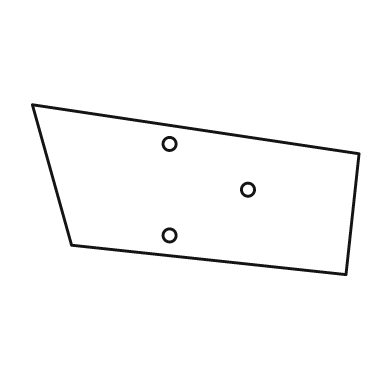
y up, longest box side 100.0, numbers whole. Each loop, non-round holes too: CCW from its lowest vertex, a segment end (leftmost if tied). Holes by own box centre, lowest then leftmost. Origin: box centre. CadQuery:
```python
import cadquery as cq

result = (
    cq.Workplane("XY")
    .moveTo(46.0, -26.0)
    .lineTo(50.0, 11.0)
    .lineTo(-50.0, 26.0)
    .lineTo(-38.0, -17.0)
    .close()
    .moveTo(-8.0, -14.0)
    .circle(2.0)
    .moveTo(16.0, 0.0)
    .circle(2.0)
    .moveTo(-8.0, 14.0)
    .circle(2.0)
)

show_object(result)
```